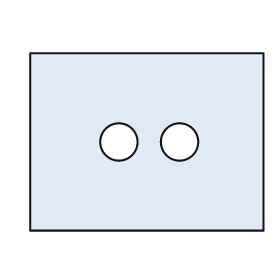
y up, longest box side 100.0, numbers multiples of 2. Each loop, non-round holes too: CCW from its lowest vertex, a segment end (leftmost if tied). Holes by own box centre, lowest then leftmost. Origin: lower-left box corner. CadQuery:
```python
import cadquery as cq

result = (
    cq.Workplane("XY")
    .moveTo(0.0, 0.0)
    .lineTo(100.0, 0.0)
    .lineTo(100.0, 76.0)
    .lineTo(0.0, 76.0)
    .close()
    .moveTo(38.0, 38.0)
    .circle(8.0)
    .moveTo(64.0, 38.0)
    .circle(8.0)
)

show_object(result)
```